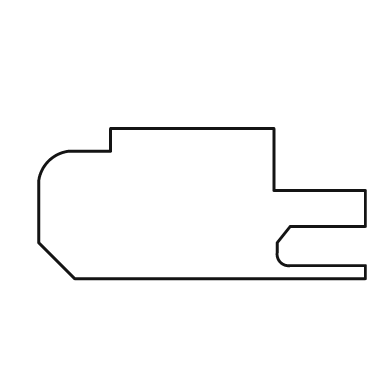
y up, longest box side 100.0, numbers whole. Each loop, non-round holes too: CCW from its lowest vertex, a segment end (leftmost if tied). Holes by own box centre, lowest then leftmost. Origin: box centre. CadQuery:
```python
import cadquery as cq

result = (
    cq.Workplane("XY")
    .moveTo(-39.0, -23.0)
    .lineTo(50.0, -23.0)
    .lineTo(50.0, -19.0)
    .lineTo(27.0, -19.0)
    .threePointArc((24.0, -18.0), (23.0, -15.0))
    .lineTo(23.0, -12.0)
    .lineTo(27.0, -7.0)
    .lineTo(50.0, -7.0)
    .lineTo(50.0, 4.0)
    .lineTo(22.0, 4.0)
    .lineTo(22.0, 23.0)
    .lineTo(-28.0, 23.0)
    .lineTo(-28.0, 16.0)
    .lineTo(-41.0, 16.0)
    .threePointArc((-47.0, 13.0), (-50.0, 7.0))
    .lineTo(-50.0, -12.0)
    .close()
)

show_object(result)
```